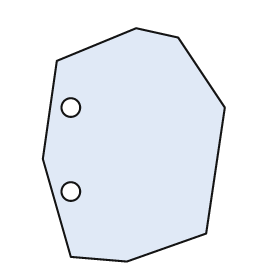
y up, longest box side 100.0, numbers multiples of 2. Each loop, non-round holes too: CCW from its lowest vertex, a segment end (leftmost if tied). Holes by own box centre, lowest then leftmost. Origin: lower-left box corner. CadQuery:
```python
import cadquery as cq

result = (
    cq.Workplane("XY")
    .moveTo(36.0, 0.0)
    .lineTo(70.0, 12.0)
    .lineTo(78.0, 66.0)
    .lineTo(58.0, 96.0)
    .lineTo(40.0, 100.0)
    .lineTo(6.0, 86.0)
    .lineTo(0.0, 44.0)
    .lineTo(12.0, 2.0)
    .close()
    .moveTo(12.0, 30.0)
    .circle(4.0)
    .moveTo(12.0, 66.0)
    .circle(4.0)
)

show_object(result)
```